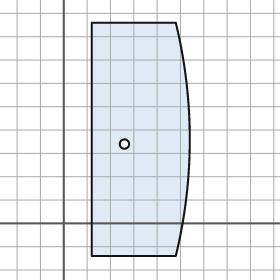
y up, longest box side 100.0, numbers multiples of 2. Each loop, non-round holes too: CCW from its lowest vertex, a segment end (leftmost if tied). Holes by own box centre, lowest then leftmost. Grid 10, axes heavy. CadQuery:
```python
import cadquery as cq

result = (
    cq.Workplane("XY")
    .moveTo(12.0, -14.0)
    .lineTo(48.0, -14.0)
    .threePointArc((54.0, 36.0), (48.0, 86.0))
    .lineTo(12.0, 86.0)
    .close()
    .moveTo(26.0, 34.0)
    .circle(2.0)
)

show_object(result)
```